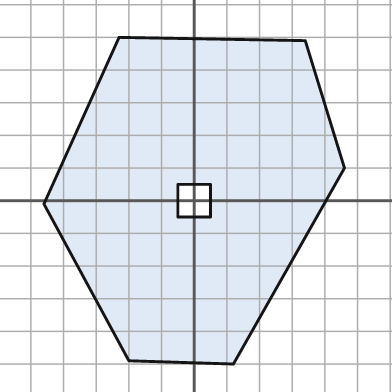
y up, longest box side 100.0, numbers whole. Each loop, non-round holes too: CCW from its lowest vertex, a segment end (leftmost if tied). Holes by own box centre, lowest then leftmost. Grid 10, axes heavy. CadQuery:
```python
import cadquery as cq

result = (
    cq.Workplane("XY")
    .moveTo(12.0, -50.0)
    .lineTo(46.0, 10.0)
    .lineTo(34.0, 49.0)
    .lineTo(-23.0, 50.0)
    .lineTo(-46.0, -1.0)
    .lineTo(-20.0, -49.0)
    .close()
    .moveTo(-5.0, -5.0)
    .lineTo(5.0, -5.0)
    .lineTo(5.0, 5.0)
    .lineTo(-5.0, 5.0)
    .close()
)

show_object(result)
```